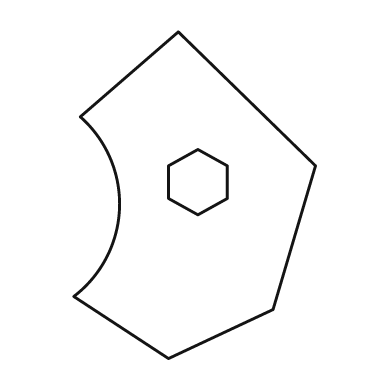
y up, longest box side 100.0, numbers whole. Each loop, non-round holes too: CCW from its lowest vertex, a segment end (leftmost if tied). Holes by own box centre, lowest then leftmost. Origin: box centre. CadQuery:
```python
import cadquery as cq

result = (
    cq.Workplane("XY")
    .moveTo(-8.0, -50.0)
    .lineTo(24.0, -35.0)
    .lineTo(37.0, 9.0)
    .lineTo(-5.0, 50.0)
    .lineTo(-35.0, 24.0)
    .threePointArc((-23.0, -4.0), (-37.0, -31.0))
    .close()
    .moveTo(1.0, -6.0)
    .lineTo(10.0, -1.0)
    .lineTo(10.0, 9.0)
    .lineTo(1.0, 14.0)
    .lineTo(-8.0, 9.0)
    .lineTo(-8.0, -1.0)
    .close()
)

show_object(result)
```